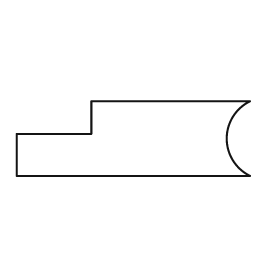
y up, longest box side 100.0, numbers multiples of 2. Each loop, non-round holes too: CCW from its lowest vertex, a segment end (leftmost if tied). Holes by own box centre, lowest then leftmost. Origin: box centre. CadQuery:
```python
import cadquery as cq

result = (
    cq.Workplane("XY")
    .moveTo(-50.0, -16.0)
    .lineTo(50.0, -16.0)
    .threePointArc((40.0, 0.0), (50.0, 16.0))
    .lineTo(-18.0, 16.0)
    .lineTo(-18.0, 2.0)
    .lineTo(-50.0, 2.0)
    .close()
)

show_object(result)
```